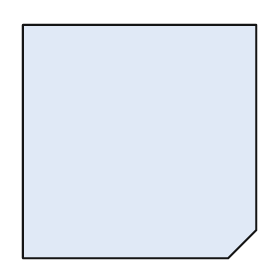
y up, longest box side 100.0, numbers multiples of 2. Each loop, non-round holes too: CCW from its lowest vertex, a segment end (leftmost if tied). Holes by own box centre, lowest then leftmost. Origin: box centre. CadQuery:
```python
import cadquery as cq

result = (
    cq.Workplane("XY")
    .moveTo(-50.0, -50.0)
    .lineTo(38.0, -50.0)
    .lineTo(50.0, -38.0)
    .lineTo(50.0, 50.0)
    .lineTo(-50.0, 50.0)
    .close()
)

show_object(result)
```